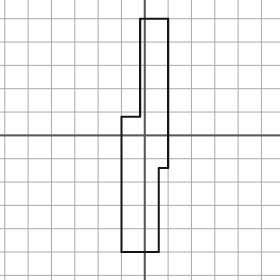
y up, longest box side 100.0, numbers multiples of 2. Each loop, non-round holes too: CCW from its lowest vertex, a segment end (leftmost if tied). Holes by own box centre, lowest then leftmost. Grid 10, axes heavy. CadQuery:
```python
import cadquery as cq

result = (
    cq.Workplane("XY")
    .moveTo(-10.0, -50.0)
    .lineTo(6.0, -50.0)
    .lineTo(6.0, -14.0)
    .lineTo(10.0, -14.0)
    .lineTo(10.0, 50.0)
    .lineTo(-2.0, 50.0)
    .lineTo(-2.0, 8.0)
    .lineTo(-10.0, 8.0)
    .close()
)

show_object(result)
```